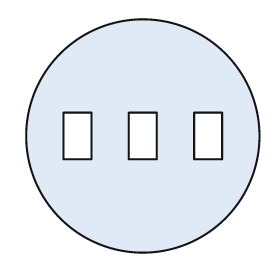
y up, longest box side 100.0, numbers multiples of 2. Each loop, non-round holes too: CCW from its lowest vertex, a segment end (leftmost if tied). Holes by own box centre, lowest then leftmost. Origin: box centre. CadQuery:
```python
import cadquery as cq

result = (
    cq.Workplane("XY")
    .moveTo(0.0, 0.0)
    .circle(50.0)
    .moveTo(-34.0, -10.0)
    .lineTo(-22.0, -10.0)
    .lineTo(-22.0, 10.0)
    .lineTo(-34.0, 10.0)
    .close()
    .moveTo(-6.0, -10.0)
    .lineTo(6.0, -10.0)
    .lineTo(6.0, 10.0)
    .lineTo(-6.0, 10.0)
    .close()
    .moveTo(22.0, -10.0)
    .lineTo(34.0, -10.0)
    .lineTo(34.0, 10.0)
    .lineTo(22.0, 10.0)
    .close()
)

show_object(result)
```